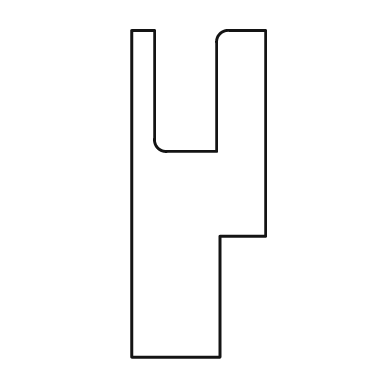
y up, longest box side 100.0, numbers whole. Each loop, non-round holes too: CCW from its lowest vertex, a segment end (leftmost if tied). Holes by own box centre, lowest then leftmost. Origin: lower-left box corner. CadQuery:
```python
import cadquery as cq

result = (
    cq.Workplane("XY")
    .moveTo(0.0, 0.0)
    .lineTo(27.0, 0.0)
    .lineTo(27.0, 37.0)
    .lineTo(41.0, 37.0)
    .lineTo(41.0, 100.0)
    .lineTo(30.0, 100.0)
    .threePointArc((27.0, 99.0), (26.0, 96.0))
    .lineTo(26.0, 63.0)
    .lineTo(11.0, 63.0)
    .threePointArc((8.0, 64.0), (7.0, 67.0))
    .lineTo(7.0, 100.0)
    .lineTo(0.0, 100.0)
    .close()
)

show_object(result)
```